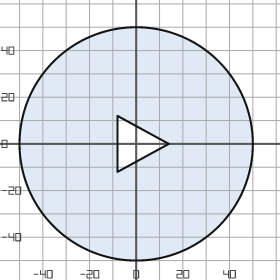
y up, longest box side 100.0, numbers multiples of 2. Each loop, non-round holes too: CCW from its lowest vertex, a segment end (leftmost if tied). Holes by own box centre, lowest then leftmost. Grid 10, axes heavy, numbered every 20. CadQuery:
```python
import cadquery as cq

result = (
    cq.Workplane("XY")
    .moveTo(0.0, 0.0)
    .circle(50.0)
    .moveTo(-8.0, -12.0)
    .lineTo(14.0, 0.0)
    .lineTo(-8.0, 12.0)
    .close()
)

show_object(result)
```